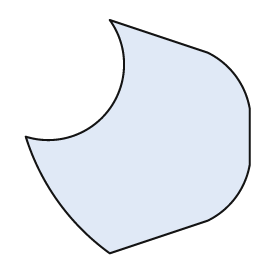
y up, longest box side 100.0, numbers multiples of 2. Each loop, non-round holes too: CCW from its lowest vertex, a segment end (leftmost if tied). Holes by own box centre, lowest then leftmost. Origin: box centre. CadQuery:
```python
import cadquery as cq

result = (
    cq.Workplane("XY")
    .moveTo(-12.0, -50.0)
    .lineTo(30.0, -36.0)
    .threePointArc((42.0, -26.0), (48.0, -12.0))
    .lineTo(48.0, 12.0)
    .threePointArc((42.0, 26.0), (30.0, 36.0))
    .lineTo(-12.0, 50.0)
    .threePointArc((-12.0, 12.0), (-48.0, 0.0))
    .threePointArc((-34.0, -28.0), (-12.0, -50.0))
    .close()
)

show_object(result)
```